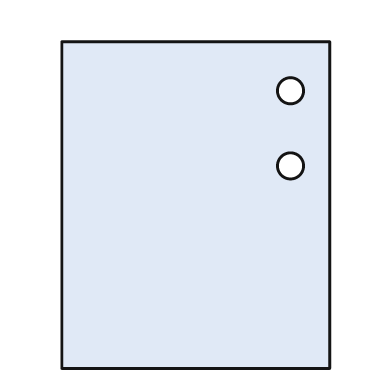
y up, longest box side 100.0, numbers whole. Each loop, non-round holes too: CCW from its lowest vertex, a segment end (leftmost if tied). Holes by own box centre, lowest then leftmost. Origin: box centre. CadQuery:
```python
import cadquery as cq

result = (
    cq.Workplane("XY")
    .moveTo(-41.0, -50.0)
    .lineTo(41.0, -50.0)
    .lineTo(41.0, 50.0)
    .lineTo(-41.0, 50.0)
    .close()
    .moveTo(29.0, 12.0)
    .circle(4.0)
    .moveTo(29.0, 35.0)
    .circle(4.0)
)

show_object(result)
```